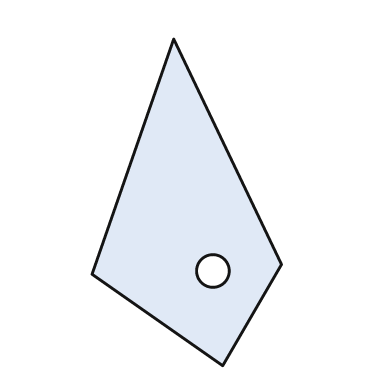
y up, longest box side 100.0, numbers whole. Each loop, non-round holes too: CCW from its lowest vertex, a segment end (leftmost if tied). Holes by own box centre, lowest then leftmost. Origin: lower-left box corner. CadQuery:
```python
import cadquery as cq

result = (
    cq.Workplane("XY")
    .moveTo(40.0, 0.0)
    .lineTo(58.0, 31.0)
    .lineTo(25.0, 100.0)
    .lineTo(0.0, 28.0)
    .close()
    .moveTo(37.0, 29.0)
    .circle(5.0)
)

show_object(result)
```